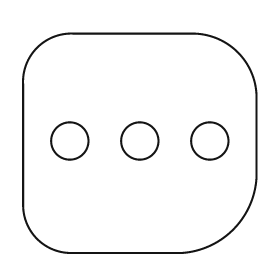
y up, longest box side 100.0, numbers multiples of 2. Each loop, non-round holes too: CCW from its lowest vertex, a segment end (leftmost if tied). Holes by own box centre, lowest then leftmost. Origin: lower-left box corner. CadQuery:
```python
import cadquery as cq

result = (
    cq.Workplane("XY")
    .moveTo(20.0, 0.0)
    .lineTo(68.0, 0.0)
    .threePointArc((90.0, 10.0), (100.0, 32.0))
    .lineTo(100.0, 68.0)
    .threePointArc((92.0, 86.0), (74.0, 94.0))
    .lineTo(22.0, 94.0)
    .threePointArc((6.0, 88.0), (0.0, 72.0))
    .lineTo(0.0, 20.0)
    .threePointArc((6.0, 6.0), (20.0, 0.0))
    .close()
    .moveTo(20.0, 48.0)
    .circle(8.0)
    .moveTo(50.0, 48.0)
    .circle(8.0)
    .moveTo(80.0, 48.0)
    .circle(8.0)
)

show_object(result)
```